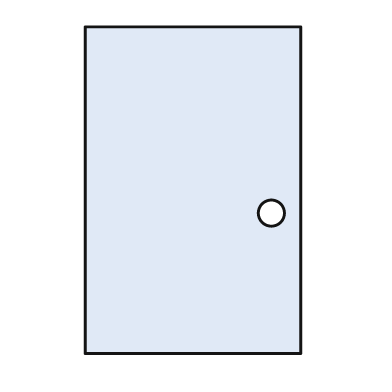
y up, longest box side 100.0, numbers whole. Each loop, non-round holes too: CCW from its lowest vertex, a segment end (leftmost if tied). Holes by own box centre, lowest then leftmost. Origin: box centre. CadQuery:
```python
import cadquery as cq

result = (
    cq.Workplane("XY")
    .moveTo(-33.0, -50.0)
    .lineTo(33.0, -50.0)
    .lineTo(33.0, 50.0)
    .lineTo(-33.0, 50.0)
    .close()
    .moveTo(24.0, -7.0)
    .circle(4.0)
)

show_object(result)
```